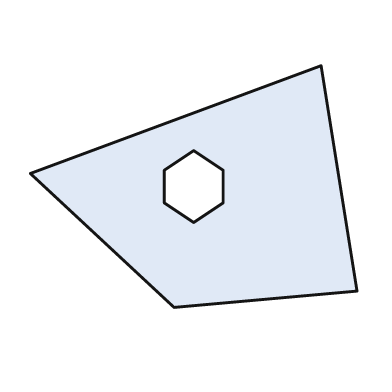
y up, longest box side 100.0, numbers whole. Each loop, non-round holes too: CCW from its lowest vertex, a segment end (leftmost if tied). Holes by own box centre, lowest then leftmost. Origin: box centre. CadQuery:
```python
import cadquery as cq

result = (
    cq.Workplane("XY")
    .moveTo(-6.0, -37.0)
    .lineTo(50.0, -32.0)
    .lineTo(39.0, 37.0)
    .lineTo(-50.0, 4.0)
    .close()
    .moveTo(0.0, -11.0)
    .lineTo(9.0, -5.0)
    .lineTo(9.0, 5.0)
    .lineTo(0.0, 11.0)
    .lineTo(-9.0, 5.0)
    .lineTo(-9.0, -5.0)
    .close()
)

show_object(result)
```